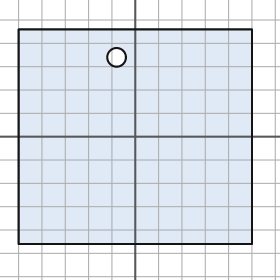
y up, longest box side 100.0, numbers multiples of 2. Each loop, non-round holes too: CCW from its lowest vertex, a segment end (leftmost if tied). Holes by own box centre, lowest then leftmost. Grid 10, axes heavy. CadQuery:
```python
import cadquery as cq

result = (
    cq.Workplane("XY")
    .moveTo(-50.0, -46.0)
    .lineTo(50.0, -46.0)
    .lineTo(50.0, 46.0)
    .lineTo(-50.0, 46.0)
    .close()
    .moveTo(-8.0, 34.0)
    .circle(4.0)
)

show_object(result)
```